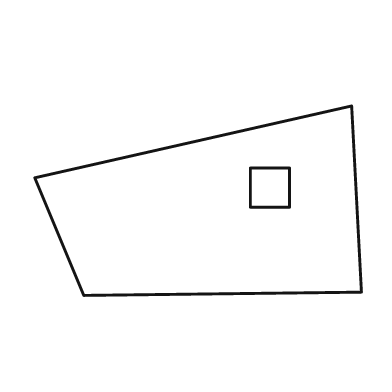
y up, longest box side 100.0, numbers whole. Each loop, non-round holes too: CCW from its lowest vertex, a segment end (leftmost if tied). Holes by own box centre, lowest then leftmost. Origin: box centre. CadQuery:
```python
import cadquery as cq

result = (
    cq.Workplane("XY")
    .moveTo(-35.0, -29.0)
    .lineTo(50.0, -28.0)
    .lineTo(47.0, 29.0)
    .lineTo(-50.0, 7.0)
    .close()
    .moveTo(16.0, -2.0)
    .lineTo(28.0, -2.0)
    .lineTo(28.0, 10.0)
    .lineTo(16.0, 10.0)
    .close()
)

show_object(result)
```